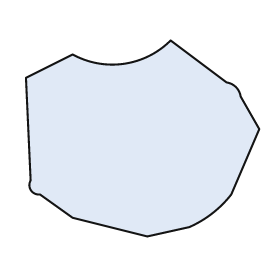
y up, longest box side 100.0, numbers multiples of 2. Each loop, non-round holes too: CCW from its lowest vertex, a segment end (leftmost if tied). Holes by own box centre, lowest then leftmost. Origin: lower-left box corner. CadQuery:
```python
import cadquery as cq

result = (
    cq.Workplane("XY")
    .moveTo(52.0, 0.0)
    .lineTo(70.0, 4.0)
    .threePointArc((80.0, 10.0), (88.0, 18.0))
    .lineTo(100.0, 46.0)
    .lineTo(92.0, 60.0)
    .threePointArc((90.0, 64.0), (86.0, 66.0))
    .lineTo(62.0, 84.0)
    .threePointArc((42.0, 74.0), (20.0, 78.0))
    .lineTo(0.0, 68.0)
    .lineTo(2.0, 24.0)
    .threePointArc((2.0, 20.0), (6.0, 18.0))
    .lineTo(20.0, 8.0)
    .close()
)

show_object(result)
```